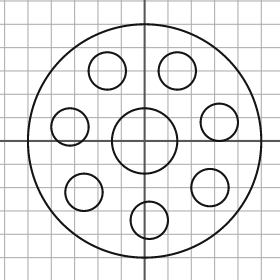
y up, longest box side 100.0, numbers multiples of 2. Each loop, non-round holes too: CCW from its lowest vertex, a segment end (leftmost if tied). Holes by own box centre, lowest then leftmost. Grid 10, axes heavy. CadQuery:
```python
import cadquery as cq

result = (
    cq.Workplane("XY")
    .moveTo(0.0, 0.0)
    .circle(50.0)
    .moveTo(2.0, -34.0)
    .circle(8.0)
    .moveTo(-26.0, -22.0)
    .circle(8.0)
    .moveTo(28.0, -20.0)
    .circle(8.0)
    .moveTo(0.0, 0.0)
    .circle(14.0)
    .moveTo(-32.0, 6.0)
    .circle(8.0)
    .moveTo(32.0, 8.0)
    .circle(8.0)
    .moveTo(-16.0, 30.0)
    .circle(8.0)
    .moveTo(14.0, 30.0)
    .circle(8.0)
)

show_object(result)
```